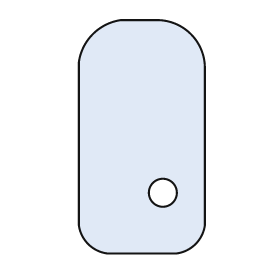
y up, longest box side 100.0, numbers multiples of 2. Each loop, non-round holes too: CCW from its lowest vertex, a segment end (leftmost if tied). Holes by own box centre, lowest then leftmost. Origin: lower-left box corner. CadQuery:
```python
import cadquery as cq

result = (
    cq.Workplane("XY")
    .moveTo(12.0, 0.0)
    .lineTo(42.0, 0.0)
    .threePointArc((50.0, 4.0), (54.0, 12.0))
    .lineTo(54.0, 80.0)
    .threePointArc((48.0, 94.0), (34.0, 100.0))
    .lineTo(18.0, 100.0)
    .threePointArc((6.0, 94.0), (0.0, 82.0))
    .lineTo(0.0, 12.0)
    .threePointArc((4.0, 4.0), (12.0, 0.0))
    .close()
    .moveTo(36.0, 26.0)
    .circle(6.0)
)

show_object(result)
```